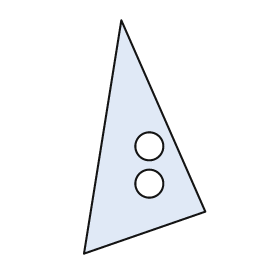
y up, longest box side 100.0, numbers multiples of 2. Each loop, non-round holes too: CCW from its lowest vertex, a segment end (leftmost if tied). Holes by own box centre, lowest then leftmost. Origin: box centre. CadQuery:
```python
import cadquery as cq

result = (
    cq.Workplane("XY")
    .moveTo(-26.0, -50.0)
    .lineTo(26.0, -32.0)
    .lineTo(-10.0, 50.0)
    .close()
    .moveTo(2.0, -20.0)
    .circle(6.0)
    .moveTo(2.0, -4.0)
    .circle(6.0)
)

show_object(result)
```